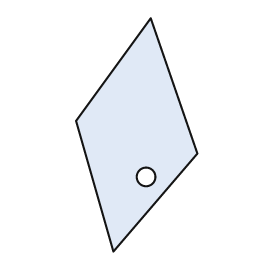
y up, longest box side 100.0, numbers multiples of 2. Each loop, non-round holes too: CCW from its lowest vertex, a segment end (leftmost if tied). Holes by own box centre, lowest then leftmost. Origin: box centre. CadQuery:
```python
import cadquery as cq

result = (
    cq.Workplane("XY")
    .moveTo(-10.0, -50.0)
    .lineTo(26.0, -8.0)
    .lineTo(6.0, 50.0)
    .lineTo(-26.0, 6.0)
    .close()
    .moveTo(4.0, -18.0)
    .circle(4.0)
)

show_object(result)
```